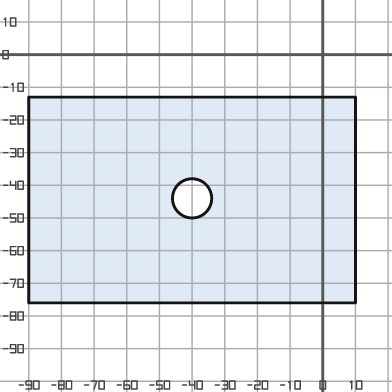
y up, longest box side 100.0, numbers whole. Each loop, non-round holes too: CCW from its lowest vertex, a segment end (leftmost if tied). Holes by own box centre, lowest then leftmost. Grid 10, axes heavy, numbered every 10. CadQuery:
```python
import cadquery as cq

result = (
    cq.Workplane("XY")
    .moveTo(-90.0, -76.0)
    .lineTo(10.0, -76.0)
    .lineTo(10.0, -13.0)
    .lineTo(-90.0, -13.0)
    .close()
    .moveTo(-40.0, -44.0)
    .circle(6.0)
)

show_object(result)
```